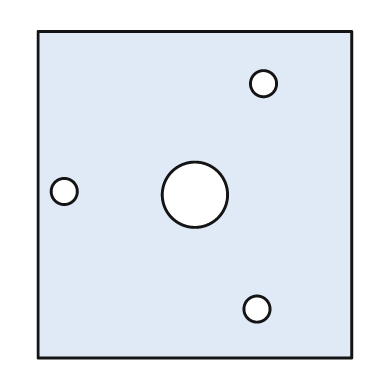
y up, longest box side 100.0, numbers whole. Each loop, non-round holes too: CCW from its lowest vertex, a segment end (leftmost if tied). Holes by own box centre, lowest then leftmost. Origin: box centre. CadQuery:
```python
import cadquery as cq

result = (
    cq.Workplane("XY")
    .moveTo(-48.0, -50.0)
    .lineTo(48.0, -50.0)
    .lineTo(48.0, 50.0)
    .lineTo(-48.0, 50.0)
    .close()
    .moveTo(19.0, -35.0)
    .circle(4.0)
    .moveTo(0.0, 0.0)
    .circle(10.0)
    .moveTo(-40.0, 1.0)
    .circle(4.0)
    .moveTo(21.0, 34.0)
    .circle(4.0)
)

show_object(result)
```